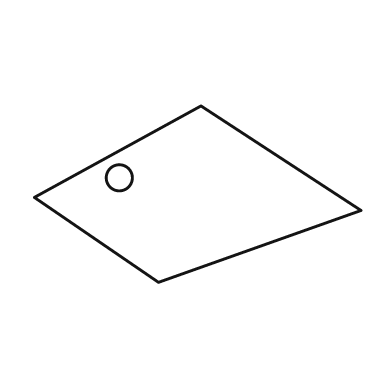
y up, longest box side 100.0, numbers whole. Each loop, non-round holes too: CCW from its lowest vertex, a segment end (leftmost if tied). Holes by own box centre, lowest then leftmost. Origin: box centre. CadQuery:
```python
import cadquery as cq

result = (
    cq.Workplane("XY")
    .moveTo(-12.0, -27.0)
    .lineTo(50.0, -5.0)
    .lineTo(1.0, 27.0)
    .lineTo(-50.0, -1.0)
    .close()
    .moveTo(-24.0, 5.0)
    .circle(4.0)
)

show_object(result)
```